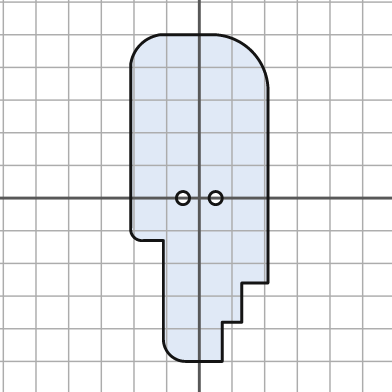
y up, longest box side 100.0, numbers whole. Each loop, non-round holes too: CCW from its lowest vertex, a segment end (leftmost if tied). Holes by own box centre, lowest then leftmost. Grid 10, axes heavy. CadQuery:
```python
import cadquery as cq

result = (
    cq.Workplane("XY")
    .moveTo(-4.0, -50.0)
    .lineTo(7.0, -50.0)
    .lineTo(7.0, -38.0)
    .lineTo(13.0, -38.0)
    .lineTo(13.0, -26.0)
    .lineTo(21.0, -26.0)
    .lineTo(21.0, 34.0)
    .threePointArc((16.0, 45.0), (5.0, 50.0))
    .lineTo(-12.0, 50.0)
    .threePointArc((-18.0, 47.0), (-21.0, 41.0))
    .lineTo(-21.0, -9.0)
    .threePointArc((-20.0, -12.0), (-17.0, -13.0))
    .lineTo(-11.0, -13.0)
    .lineTo(-11.0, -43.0)
    .threePointArc((-9.0, -48.0), (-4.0, -50.0))
    .close()
    .moveTo(-5.0, 0.0)
    .circle(2.0)
    .moveTo(5.0, 0.0)
    .circle(2.0)
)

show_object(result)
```